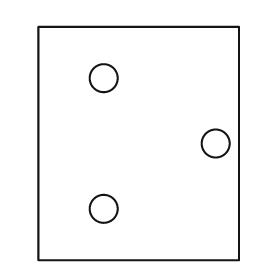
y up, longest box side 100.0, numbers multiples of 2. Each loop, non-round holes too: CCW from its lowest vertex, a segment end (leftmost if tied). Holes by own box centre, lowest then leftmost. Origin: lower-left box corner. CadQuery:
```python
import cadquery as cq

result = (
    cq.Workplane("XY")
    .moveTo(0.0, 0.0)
    .lineTo(86.0, 0.0)
    .lineTo(86.0, 100.0)
    .lineTo(0.0, 100.0)
    .close()
    .moveTo(28.0, 22.0)
    .circle(6.0)
    .moveTo(76.0, 50.0)
    .circle(6.0)
    .moveTo(28.0, 78.0)
    .circle(6.0)
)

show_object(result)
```